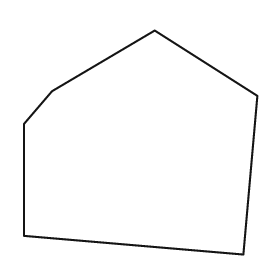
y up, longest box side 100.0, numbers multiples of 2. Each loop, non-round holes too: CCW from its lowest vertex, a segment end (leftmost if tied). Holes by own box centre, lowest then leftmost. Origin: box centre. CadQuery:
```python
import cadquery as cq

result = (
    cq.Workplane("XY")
    .moveTo(44.0, -48.0)
    .lineTo(50.0, 20.0)
    .lineTo(6.0, 48.0)
    .lineTo(-38.0, 22.0)
    .lineTo(-50.0, 8.0)
    .lineTo(-50.0, -40.0)
    .close()
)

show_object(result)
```